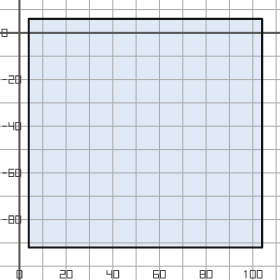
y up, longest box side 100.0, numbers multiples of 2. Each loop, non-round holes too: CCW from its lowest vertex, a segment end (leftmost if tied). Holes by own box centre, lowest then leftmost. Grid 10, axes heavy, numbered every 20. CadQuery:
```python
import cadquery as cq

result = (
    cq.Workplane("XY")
    .moveTo(4.0, -92.0)
    .lineTo(104.0, -92.0)
    .lineTo(104.0, 6.0)
    .lineTo(4.0, 6.0)
    .close()
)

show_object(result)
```